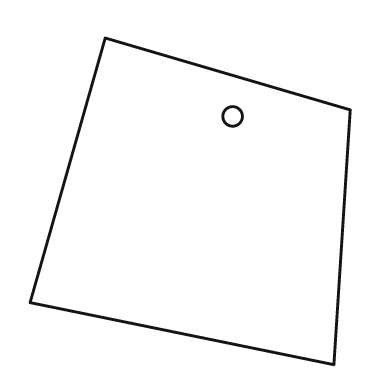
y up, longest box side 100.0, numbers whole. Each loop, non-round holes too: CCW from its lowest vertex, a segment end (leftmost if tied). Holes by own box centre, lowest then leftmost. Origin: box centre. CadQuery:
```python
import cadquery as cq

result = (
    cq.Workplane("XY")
    .moveTo(44.0, -50.0)
    .lineTo(49.0, 28.0)
    .lineTo(-26.0, 50.0)
    .lineTo(-49.0, -31.0)
    .close()
    .moveTo(13.0, 26.0)
    .circle(3.0)
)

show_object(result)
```